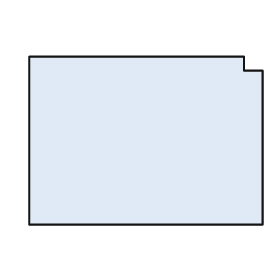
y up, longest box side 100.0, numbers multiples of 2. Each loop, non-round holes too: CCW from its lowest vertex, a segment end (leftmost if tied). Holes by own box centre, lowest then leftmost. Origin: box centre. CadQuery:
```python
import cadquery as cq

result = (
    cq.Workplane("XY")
    .moveTo(-50.0, -36.0)
    .lineTo(50.0, -36.0)
    .lineTo(50.0, 30.0)
    .lineTo(42.0, 30.0)
    .lineTo(42.0, 36.0)
    .lineTo(-50.0, 36.0)
    .close()
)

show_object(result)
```